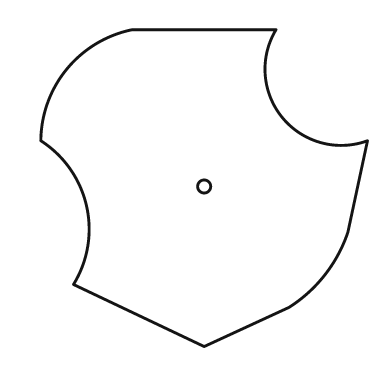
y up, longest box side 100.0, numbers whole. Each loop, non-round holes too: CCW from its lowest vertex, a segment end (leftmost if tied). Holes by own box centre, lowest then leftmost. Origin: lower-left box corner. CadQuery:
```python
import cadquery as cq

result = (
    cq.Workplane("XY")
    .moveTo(50.0, 0.0)
    .lineTo(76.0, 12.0)
    .threePointArc((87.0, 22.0), (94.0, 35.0))
    .lineTo(100.0, 63.0)
    .threePointArc((74.0, 70.0), (72.0, 97.0))
    .lineTo(28.0, 97.0)
    .threePointArc((8.0, 85.0), (0.0, 63.0))
    .threePointArc((14.0, 43.0), (10.0, 19.0))
    .close()
    .moveTo(50.0, 49.0)
    .circle(2.0)
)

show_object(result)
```